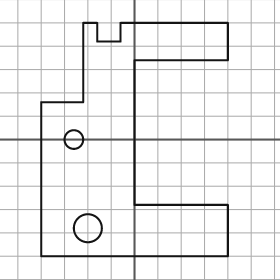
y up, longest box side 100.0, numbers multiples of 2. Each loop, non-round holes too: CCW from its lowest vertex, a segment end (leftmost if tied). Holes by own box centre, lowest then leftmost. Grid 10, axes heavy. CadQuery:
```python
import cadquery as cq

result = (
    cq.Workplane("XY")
    .moveTo(-40.0, -50.0)
    .lineTo(40.0, -50.0)
    .lineTo(40.0, -28.0)
    .lineTo(0.0, -28.0)
    .lineTo(0.0, 34.0)
    .lineTo(40.0, 34.0)
    .lineTo(40.0, 50.0)
    .lineTo(-6.0, 50.0)
    .lineTo(-6.0, 42.0)
    .lineTo(-16.0, 42.0)
    .lineTo(-16.0, 50.0)
    .lineTo(-22.0, 50.0)
    .lineTo(-22.0, 16.0)
    .lineTo(-40.0, 16.0)
    .close()
    .moveTo(-20.0, -38.0)
    .circle(6.0)
    .moveTo(-26.0, 0.0)
    .circle(4.0)
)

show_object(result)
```